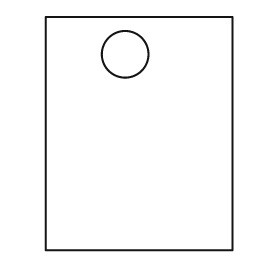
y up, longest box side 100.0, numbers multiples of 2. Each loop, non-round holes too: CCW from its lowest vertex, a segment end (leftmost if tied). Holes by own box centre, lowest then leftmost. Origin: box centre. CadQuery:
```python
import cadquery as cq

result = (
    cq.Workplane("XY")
    .moveTo(-40.0, -50.0)
    .lineTo(40.0, -50.0)
    .lineTo(40.0, 50.0)
    .lineTo(-40.0, 50.0)
    .close()
    .moveTo(-6.0, 34.0)
    .circle(10.0)
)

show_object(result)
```